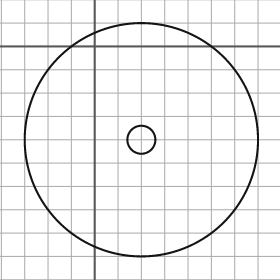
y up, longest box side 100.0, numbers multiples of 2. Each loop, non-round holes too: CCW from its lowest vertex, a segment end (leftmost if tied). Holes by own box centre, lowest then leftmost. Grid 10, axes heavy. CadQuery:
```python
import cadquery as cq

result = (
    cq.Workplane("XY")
    .moveTo(20.0, -40.0)
    .circle(50.0)
    .moveTo(20.0, -40.0)
    .circle(6.0)
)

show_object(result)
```